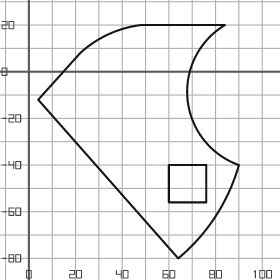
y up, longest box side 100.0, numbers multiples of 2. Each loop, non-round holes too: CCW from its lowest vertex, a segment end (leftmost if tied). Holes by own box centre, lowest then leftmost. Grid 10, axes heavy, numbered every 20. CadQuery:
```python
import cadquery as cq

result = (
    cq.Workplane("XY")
    .moveTo(64.0, -80.0)
    .threePointArc((80.0, -62.0), (90.0, -40.0))
    .threePointArc((68.0, -12.0), (84.0, 20.0))
    .lineTo(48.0, 20.0)
    .threePointArc((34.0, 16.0), (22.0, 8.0))
    .lineTo(4.0, -12.0)
    .close()
    .moveTo(60.0, -56.0)
    .lineTo(76.0, -56.0)
    .lineTo(76.0, -40.0)
    .lineTo(60.0, -40.0)
    .close()
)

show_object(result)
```